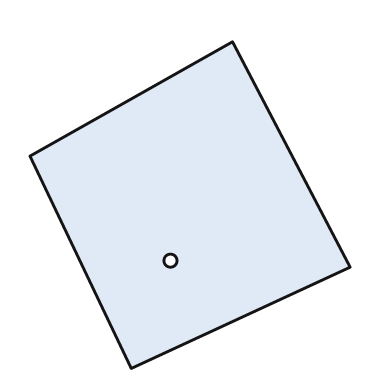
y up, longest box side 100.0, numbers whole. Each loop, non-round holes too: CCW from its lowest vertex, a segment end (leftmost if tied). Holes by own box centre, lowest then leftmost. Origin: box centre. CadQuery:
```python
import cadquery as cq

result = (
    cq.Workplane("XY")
    .moveTo(-18.0, -50.0)
    .lineTo(49.0, -19.0)
    .lineTo(13.0, 50.0)
    .lineTo(-49.0, 15.0)
    .close()
    .moveTo(-6.0, -17.0)
    .circle(2.0)
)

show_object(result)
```